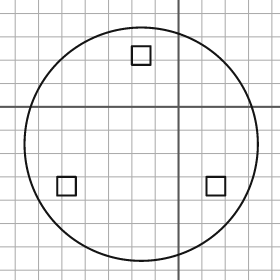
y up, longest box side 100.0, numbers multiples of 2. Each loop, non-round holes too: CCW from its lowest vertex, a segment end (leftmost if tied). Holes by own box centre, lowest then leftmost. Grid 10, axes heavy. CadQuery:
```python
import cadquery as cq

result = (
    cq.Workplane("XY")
    .moveTo(-16.0, -16.0)
    .circle(50.0)
    .moveTo(-52.0, -38.0)
    .lineTo(-44.0, -38.0)
    .lineTo(-44.0, -30.0)
    .lineTo(-52.0, -30.0)
    .close()
    .moveTo(12.0, -38.0)
    .lineTo(20.0, -38.0)
    .lineTo(20.0, -30.0)
    .lineTo(12.0, -30.0)
    .close()
    .moveTo(-20.0, 18.0)
    .lineTo(-12.0, 18.0)
    .lineTo(-12.0, 26.0)
    .lineTo(-20.0, 26.0)
    .close()
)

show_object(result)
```